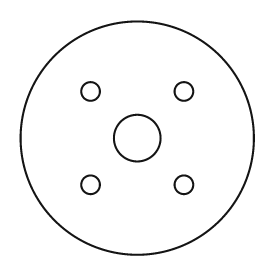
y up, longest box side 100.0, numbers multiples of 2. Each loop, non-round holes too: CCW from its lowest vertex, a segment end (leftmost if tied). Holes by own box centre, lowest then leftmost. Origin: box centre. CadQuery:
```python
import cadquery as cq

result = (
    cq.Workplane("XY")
    .moveTo(0.0, 0.0)
    .circle(50.0)
    .moveTo(-20.0, -20.0)
    .circle(4.0)
    .moveTo(20.0, -20.0)
    .circle(4.0)
    .moveTo(0.0, 0.0)
    .circle(10.0)
    .moveTo(-20.0, 20.0)
    .circle(4.0)
    .moveTo(20.0, 20.0)
    .circle(4.0)
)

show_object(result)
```